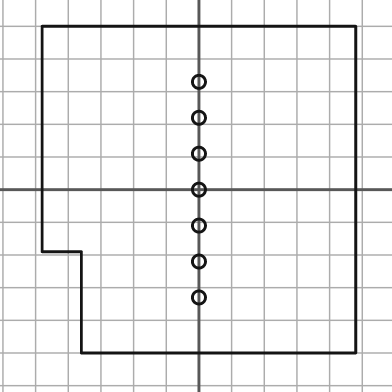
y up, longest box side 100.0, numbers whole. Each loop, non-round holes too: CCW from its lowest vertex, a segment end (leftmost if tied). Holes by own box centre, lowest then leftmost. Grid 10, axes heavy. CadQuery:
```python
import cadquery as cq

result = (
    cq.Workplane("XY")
    .moveTo(-36.0, -50.0)
    .lineTo(48.0, -50.0)
    .lineTo(48.0, 50.0)
    .lineTo(-48.0, 50.0)
    .lineTo(-48.0, -19.0)
    .lineTo(-36.0, -19.0)
    .close()
    .moveTo(0.0, -33.0)
    .circle(2.0)
    .moveTo(0.0, -22.0)
    .circle(2.0)
    .moveTo(0.0, -11.0)
    .circle(2.0)
    .moveTo(0.0, 0.0)
    .circle(2.0)
    .moveTo(0.0, 11.0)
    .circle(2.0)
    .moveTo(0.0, 22.0)
    .circle(2.0)
    .moveTo(0.0, 33.0)
    .circle(2.0)
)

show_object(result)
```